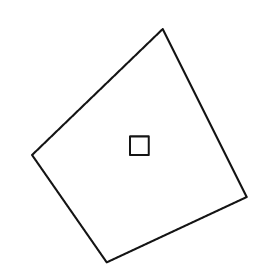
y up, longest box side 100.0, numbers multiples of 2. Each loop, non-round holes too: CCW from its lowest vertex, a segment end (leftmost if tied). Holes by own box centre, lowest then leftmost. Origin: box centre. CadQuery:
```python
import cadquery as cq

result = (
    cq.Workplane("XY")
    .moveTo(-14.0, -50.0)
    .lineTo(46.0, -22.0)
    .lineTo(10.0, 50.0)
    .lineTo(-46.0, -4.0)
    .close()
    .moveTo(-4.0, -4.0)
    .lineTo(4.0, -4.0)
    .lineTo(4.0, 4.0)
    .lineTo(-4.0, 4.0)
    .close()
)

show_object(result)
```